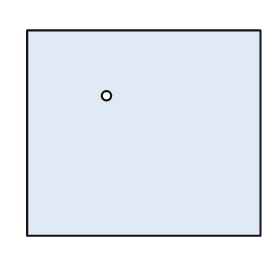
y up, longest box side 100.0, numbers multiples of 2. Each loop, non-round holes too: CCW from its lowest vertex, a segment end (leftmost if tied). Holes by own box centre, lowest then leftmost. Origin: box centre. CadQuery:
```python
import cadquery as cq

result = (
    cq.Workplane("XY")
    .moveTo(-50.0, -44.0)
    .lineTo(50.0, -44.0)
    .lineTo(50.0, 44.0)
    .lineTo(-50.0, 44.0)
    .close()
    .moveTo(-16.0, 16.0)
    .circle(2.0)
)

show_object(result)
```